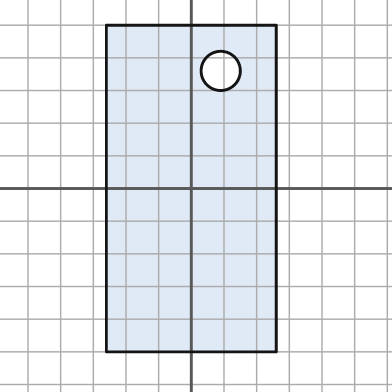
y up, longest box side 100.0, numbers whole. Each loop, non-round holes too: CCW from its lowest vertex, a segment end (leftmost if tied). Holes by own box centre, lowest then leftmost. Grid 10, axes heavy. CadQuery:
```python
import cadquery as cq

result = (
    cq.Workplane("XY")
    .moveTo(-26.0, -50.0)
    .lineTo(26.0, -50.0)
    .lineTo(26.0, 50.0)
    .lineTo(-26.0, 50.0)
    .close()
    .moveTo(9.0, 36.0)
    .circle(6.0)
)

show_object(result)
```